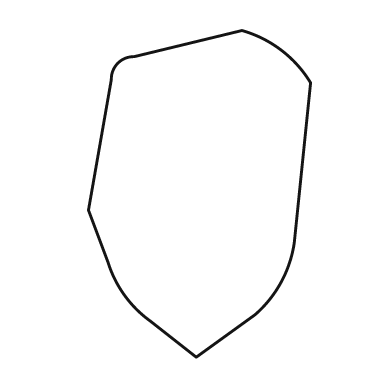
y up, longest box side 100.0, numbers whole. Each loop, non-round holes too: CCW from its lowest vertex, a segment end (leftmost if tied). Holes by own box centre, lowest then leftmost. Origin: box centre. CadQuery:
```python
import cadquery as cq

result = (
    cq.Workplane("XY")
    .moveTo(-1.0, -50.0)
    .lineTo(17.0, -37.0)
    .threePointArc((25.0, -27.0), (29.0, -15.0))
    .lineTo(34.0, 34.0)
    .threePointArc((25.0, 44.0), (13.0, 50.0))
    .lineTo(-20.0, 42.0)
    .threePointArc((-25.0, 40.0), (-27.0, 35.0))
    .lineTo(-34.0, -5.0)
    .lineTo(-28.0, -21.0)
    .threePointArc((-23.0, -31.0), (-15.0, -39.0))
    .close()
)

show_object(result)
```